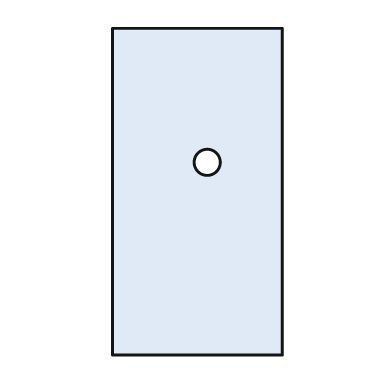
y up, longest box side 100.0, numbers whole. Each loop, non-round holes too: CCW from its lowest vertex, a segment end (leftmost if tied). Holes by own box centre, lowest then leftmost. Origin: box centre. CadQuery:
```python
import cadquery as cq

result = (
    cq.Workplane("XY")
    .moveTo(-26.0, -50.0)
    .lineTo(26.0, -50.0)
    .lineTo(26.0, 50.0)
    .lineTo(-26.0, 50.0)
    .close()
    .moveTo(3.0, 9.0)
    .circle(4.0)
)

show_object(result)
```